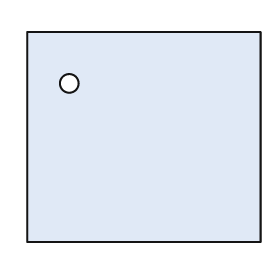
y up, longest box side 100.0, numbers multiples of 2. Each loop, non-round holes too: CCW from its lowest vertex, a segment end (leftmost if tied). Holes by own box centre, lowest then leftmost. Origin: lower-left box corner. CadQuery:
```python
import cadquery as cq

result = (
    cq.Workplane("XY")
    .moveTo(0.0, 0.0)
    .lineTo(100.0, 0.0)
    .lineTo(100.0, 90.0)
    .lineTo(0.0, 90.0)
    .close()
    .moveTo(18.0, 68.0)
    .circle(4.0)
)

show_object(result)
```